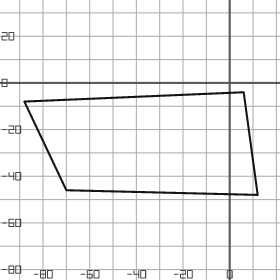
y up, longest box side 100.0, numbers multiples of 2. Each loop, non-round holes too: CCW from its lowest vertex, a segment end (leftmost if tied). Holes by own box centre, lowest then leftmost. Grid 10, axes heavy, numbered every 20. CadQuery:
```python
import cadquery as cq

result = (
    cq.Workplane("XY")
    .moveTo(12.0, -48.0)
    .lineTo(6.0, -4.0)
    .lineTo(-88.0, -8.0)
    .lineTo(-70.0, -46.0)
    .close()
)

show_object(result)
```